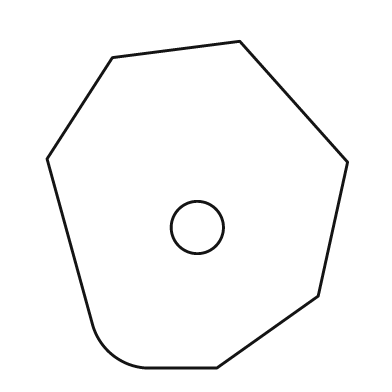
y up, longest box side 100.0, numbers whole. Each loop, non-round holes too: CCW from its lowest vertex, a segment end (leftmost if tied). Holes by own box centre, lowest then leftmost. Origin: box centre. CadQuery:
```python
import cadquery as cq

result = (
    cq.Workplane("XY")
    .moveTo(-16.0, -50.0)
    .lineTo(6.0, -50.0)
    .lineTo(37.0, -28.0)
    .lineTo(46.0, 13.0)
    .lineTo(13.0, 50.0)
    .lineTo(-26.0, 45.0)
    .lineTo(-46.0, 14.0)
    .lineTo(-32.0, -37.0)
    .threePointArc((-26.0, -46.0), (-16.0, -50.0))
    .close()
    .moveTo(0.0, -7.0)
    .circle(8.0)
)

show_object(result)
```